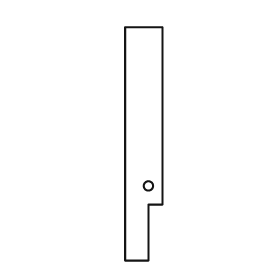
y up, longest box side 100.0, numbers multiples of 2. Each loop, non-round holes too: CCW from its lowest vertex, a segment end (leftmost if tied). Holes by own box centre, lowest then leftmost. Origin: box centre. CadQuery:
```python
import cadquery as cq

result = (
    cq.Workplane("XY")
    .moveTo(-8.0, -50.0)
    .lineTo(2.0, -50.0)
    .lineTo(2.0, -26.0)
    .lineTo(8.0, -26.0)
    .lineTo(8.0, 50.0)
    .lineTo(-8.0, 50.0)
    .close()
    .moveTo(2.0, -18.0)
    .circle(2.0)
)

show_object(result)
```